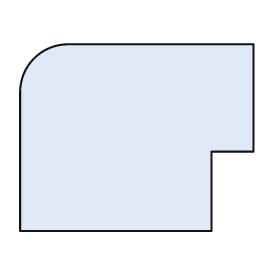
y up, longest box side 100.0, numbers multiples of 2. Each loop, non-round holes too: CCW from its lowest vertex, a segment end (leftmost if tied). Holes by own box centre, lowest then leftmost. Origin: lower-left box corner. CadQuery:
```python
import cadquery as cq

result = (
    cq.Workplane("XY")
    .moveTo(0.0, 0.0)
    .lineTo(82.0, 0.0)
    .lineTo(82.0, 34.0)
    .lineTo(100.0, 34.0)
    .lineTo(100.0, 80.0)
    .lineTo(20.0, 80.0)
    .threePointArc((6.0, 74.0), (0.0, 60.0))
    .close()
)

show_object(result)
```